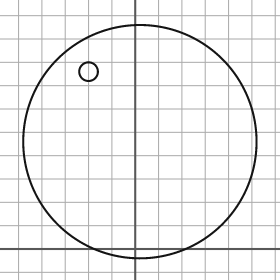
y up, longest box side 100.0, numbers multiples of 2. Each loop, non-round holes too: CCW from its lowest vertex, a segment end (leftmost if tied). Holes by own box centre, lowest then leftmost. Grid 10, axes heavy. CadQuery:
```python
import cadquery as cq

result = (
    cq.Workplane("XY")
    .moveTo(2.0, 46.0)
    .circle(50.0)
    .moveTo(-20.0, 76.0)
    .circle(4.0)
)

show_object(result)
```